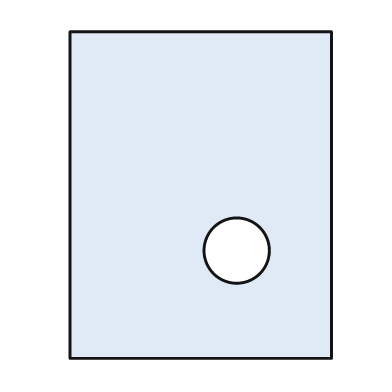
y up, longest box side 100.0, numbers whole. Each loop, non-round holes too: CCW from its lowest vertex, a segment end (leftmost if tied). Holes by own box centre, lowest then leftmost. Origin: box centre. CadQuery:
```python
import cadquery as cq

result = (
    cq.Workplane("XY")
    .moveTo(-40.0, -50.0)
    .lineTo(40.0, -50.0)
    .lineTo(40.0, 50.0)
    .lineTo(-40.0, 50.0)
    .close()
    .moveTo(11.0, -17.0)
    .circle(10.0)
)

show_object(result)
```